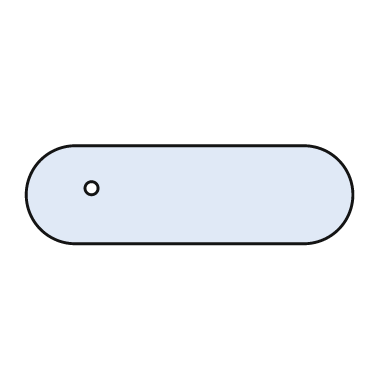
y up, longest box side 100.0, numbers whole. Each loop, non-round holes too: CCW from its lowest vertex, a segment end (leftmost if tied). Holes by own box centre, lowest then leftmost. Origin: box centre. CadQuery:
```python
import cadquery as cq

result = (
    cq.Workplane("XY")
    .moveTo(-35.0, -15.0)
    .lineTo(35.0, -15.0)
    .threePointArc((50.0, 0.0), (35.0, 15.0))
    .lineTo(-35.0, 15.0)
    .threePointArc((-50.0, 0.0), (-35.0, -15.0))
    .close()
    .moveTo(-30.0, 2.0)
    .circle(2.0)
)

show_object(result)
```